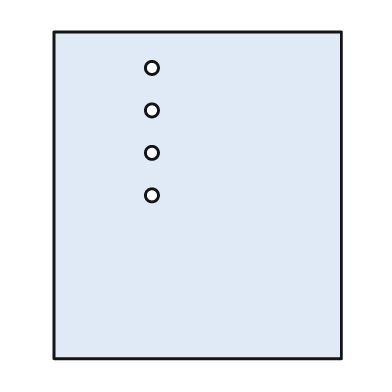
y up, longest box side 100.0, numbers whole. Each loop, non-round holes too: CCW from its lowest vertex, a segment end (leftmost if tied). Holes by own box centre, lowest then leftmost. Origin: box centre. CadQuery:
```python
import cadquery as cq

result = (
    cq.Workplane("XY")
    .moveTo(-44.0, -50.0)
    .lineTo(44.0, -50.0)
    .lineTo(44.0, 50.0)
    .lineTo(-44.0, 50.0)
    .close()
    .moveTo(-14.0, 0.0)
    .circle(2.0)
    .moveTo(-14.0, 13.0)
    .circle(2.0)
    .moveTo(-14.0, 26.0)
    .circle(2.0)
    .moveTo(-14.0, 39.0)
    .circle(2.0)
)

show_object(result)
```